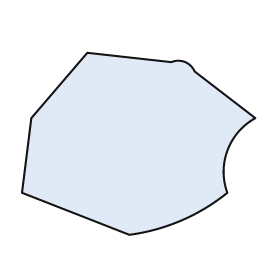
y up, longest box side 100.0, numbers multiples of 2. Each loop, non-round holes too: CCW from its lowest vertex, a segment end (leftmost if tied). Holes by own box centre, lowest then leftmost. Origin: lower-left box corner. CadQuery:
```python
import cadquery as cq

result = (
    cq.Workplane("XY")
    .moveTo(46.0, 0.0)
    .threePointArc((68.0, 6.0), (88.0, 18.0))
    .threePointArc((88.0, 36.0), (100.0, 50.0))
    .lineTo(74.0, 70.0)
    .threePointArc((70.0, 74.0), (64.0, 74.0))
    .lineTo(28.0, 78.0)
    .lineTo(4.0, 50.0)
    .lineTo(0.0, 18.0)
    .close()
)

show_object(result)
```